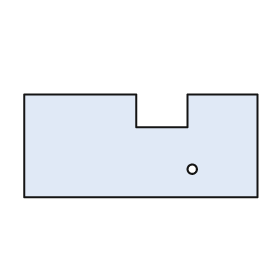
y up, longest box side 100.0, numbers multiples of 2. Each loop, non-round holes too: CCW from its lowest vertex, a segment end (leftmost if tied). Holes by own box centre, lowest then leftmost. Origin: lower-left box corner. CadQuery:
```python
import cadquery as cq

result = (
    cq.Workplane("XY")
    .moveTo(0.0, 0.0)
    .lineTo(100.0, 0.0)
    .lineTo(100.0, 44.0)
    .lineTo(70.0, 44.0)
    .lineTo(70.0, 30.0)
    .lineTo(48.0, 30.0)
    .lineTo(48.0, 44.0)
    .lineTo(0.0, 44.0)
    .close()
    .moveTo(72.0, 12.0)
    .circle(2.0)
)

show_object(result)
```